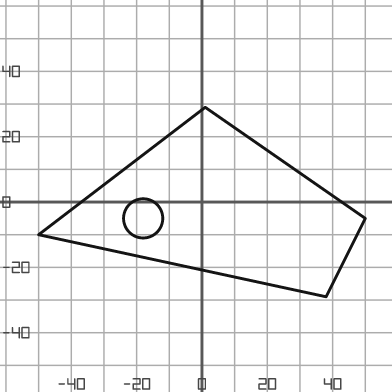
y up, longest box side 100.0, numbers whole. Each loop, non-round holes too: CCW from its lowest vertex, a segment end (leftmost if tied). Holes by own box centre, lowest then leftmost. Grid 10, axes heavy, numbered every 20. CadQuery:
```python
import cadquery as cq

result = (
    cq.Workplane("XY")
    .moveTo(38.0, -29.0)
    .lineTo(50.0, -5.0)
    .lineTo(1.0, 29.0)
    .lineTo(-50.0, -10.0)
    .close()
    .moveTo(-18.0, -5.0)
    .circle(6.0)
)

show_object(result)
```